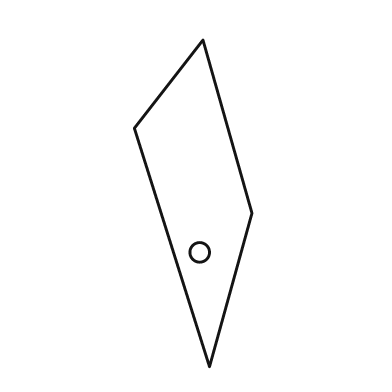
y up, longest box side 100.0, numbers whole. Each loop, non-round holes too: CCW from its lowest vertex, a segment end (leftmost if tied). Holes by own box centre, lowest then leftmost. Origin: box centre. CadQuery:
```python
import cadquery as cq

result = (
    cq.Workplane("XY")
    .moveTo(5.0, -50.0)
    .lineTo(18.0, -3.0)
    .lineTo(3.0, 50.0)
    .lineTo(-18.0, 23.0)
    .close()
    .moveTo(2.0, -15.0)
    .circle(3.0)
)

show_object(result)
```